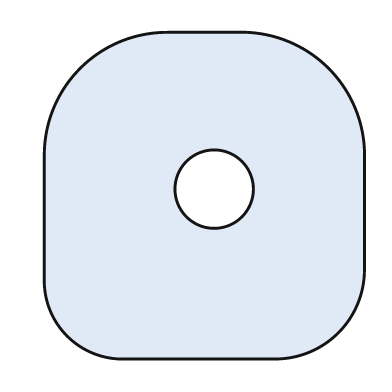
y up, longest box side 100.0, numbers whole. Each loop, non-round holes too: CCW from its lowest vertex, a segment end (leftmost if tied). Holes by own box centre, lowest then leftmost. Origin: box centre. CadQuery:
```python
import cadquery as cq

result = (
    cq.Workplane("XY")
    .moveTo(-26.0, -50.0)
    .lineTo(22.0, -50.0)
    .threePointArc((41.0, -42.0), (49.0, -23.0))
    .lineTo(49.0, 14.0)
    .threePointArc((38.0, 39.0), (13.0, 50.0))
    .lineTo(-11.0, 50.0)
    .threePointArc((-38.0, 39.0), (-49.0, 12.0))
    .lineTo(-49.0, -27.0)
    .threePointArc((-42.0, -43.0), (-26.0, -50.0))
    .close()
    .moveTo(3.0, 2.0)
    .circle(12.0)
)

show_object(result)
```